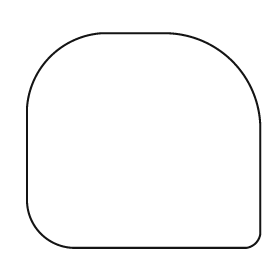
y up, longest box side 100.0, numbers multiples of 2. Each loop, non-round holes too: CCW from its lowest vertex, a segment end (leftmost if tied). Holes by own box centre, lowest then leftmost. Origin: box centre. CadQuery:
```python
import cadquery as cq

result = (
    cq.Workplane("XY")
    .moveTo(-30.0, -46.0)
    .lineTo(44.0, -46.0)
    .threePointArc((48.0, -44.0), (50.0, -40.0))
    .lineTo(50.0, 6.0)
    .threePointArc((38.0, 34.0), (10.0, 46.0))
    .lineTo(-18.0, 46.0)
    .threePointArc((-40.0, 36.0), (-50.0, 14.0))
    .lineTo(-50.0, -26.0)
    .threePointArc((-44.0, -40.0), (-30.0, -46.0))
    .close()
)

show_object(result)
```